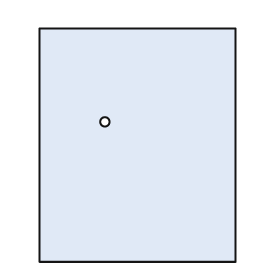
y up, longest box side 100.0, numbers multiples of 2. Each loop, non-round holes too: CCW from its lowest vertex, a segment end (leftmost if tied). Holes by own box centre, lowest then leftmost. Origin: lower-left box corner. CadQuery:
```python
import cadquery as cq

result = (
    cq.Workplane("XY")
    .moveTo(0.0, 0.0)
    .lineTo(84.0, 0.0)
    .lineTo(84.0, 100.0)
    .lineTo(0.0, 100.0)
    .close()
    .moveTo(28.0, 60.0)
    .circle(2.0)
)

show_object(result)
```